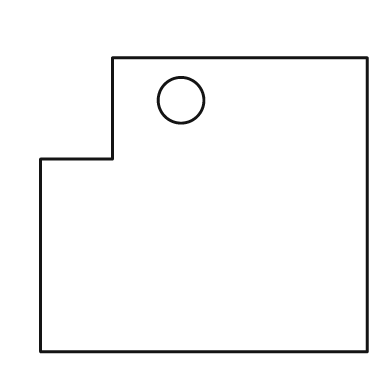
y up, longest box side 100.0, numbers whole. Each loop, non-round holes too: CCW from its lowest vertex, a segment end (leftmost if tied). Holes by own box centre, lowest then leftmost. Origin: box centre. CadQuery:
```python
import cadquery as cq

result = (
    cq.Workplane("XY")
    .moveTo(-50.0, -45.0)
    .lineTo(50.0, -45.0)
    .lineTo(50.0, 45.0)
    .lineTo(-28.0, 45.0)
    .lineTo(-28.0, 14.0)
    .lineTo(-50.0, 14.0)
    .close()
    .moveTo(-7.0, 32.0)
    .circle(7.0)
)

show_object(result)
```